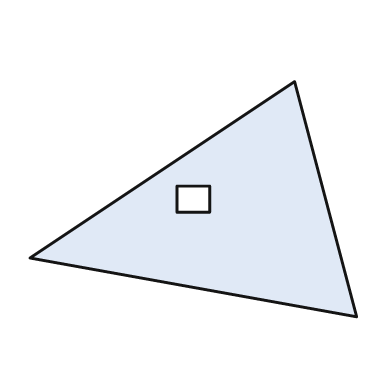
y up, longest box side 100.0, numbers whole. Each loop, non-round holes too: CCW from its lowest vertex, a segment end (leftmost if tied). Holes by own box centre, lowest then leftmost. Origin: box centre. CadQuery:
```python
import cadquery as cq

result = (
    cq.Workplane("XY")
    .moveTo(50.0, -36.0)
    .lineTo(31.0, 36.0)
    .lineTo(-50.0, -18.0)
    .close()
    .moveTo(-5.0, -4.0)
    .lineTo(5.0, -4.0)
    .lineTo(5.0, 4.0)
    .lineTo(-5.0, 4.0)
    .close()
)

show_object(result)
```